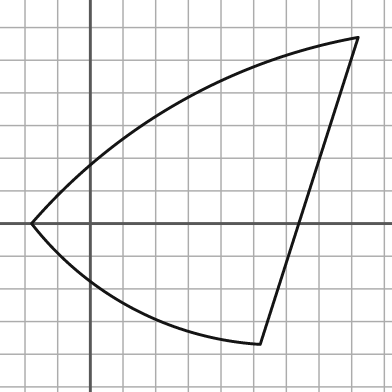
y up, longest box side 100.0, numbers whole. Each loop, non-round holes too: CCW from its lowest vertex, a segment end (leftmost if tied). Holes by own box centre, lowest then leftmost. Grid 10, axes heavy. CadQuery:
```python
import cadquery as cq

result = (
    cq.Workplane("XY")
    .moveTo(52.0, -37.0)
    .lineTo(82.0, 57.0)
    .threePointArc((27.0, 37.0), (-18.0, 0.0))
    .threePointArc((13.0, -26.0), (52.0, -37.0))
    .close()
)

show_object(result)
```